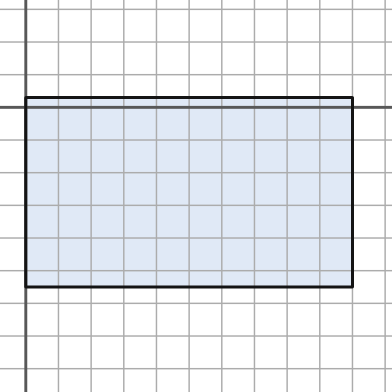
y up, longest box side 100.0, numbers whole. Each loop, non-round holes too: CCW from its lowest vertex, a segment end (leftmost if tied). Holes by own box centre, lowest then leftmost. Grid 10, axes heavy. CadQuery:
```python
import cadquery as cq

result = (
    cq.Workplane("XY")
    .moveTo(0.0, -55.0)
    .lineTo(100.0, -55.0)
    .lineTo(100.0, 3.0)
    .lineTo(0.0, 3.0)
    .close()
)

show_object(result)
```